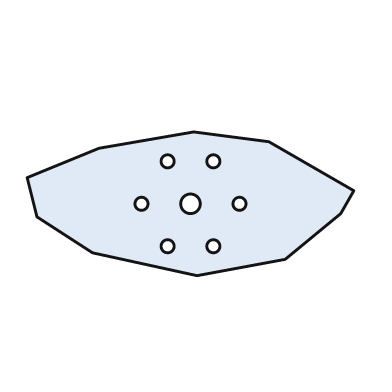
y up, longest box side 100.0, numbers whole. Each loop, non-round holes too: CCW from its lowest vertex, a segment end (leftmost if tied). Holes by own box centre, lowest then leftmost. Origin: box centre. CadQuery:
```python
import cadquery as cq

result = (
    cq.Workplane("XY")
    .moveTo(2.0, -22.0)
    .lineTo(29.0, -17.0)
    .lineTo(46.0, -3.0)
    .lineTo(50.0, 4.0)
    .lineTo(24.0, 19.0)
    .lineTo(1.0, 22.0)
    .lineTo(-28.0, 17.0)
    .lineTo(-50.0, 8.0)
    .lineTo(-47.0, -4.0)
    .lineTo(-30.0, -15.0)
    .close()
    .moveTo(-7.0, -13.0)
    .circle(2.0)
    .moveTo(7.0, -13.0)
    .circle(2.0)
    .moveTo(-15.0, 0.0)
    .circle(2.0)
    .moveTo(0.0, 0.0)
    .circle(3.0)
    .moveTo(15.0, 0.0)
    .circle(2.0)
    .moveTo(-7.0, 13.0)
    .circle(2.0)
    .moveTo(7.0, 13.0)
    .circle(2.0)
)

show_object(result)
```